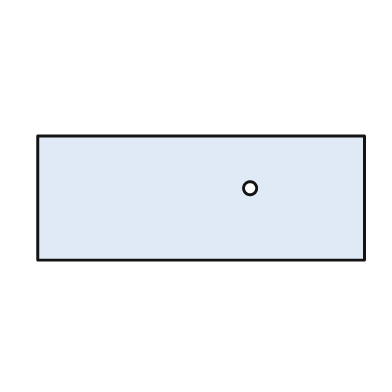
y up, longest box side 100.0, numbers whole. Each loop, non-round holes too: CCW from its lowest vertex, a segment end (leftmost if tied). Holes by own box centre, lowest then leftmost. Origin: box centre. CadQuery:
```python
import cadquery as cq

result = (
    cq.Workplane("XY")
    .moveTo(-50.0, -19.0)
    .lineTo(50.0, -19.0)
    .lineTo(50.0, 19.0)
    .lineTo(-50.0, 19.0)
    .close()
    .moveTo(15.0, 3.0)
    .circle(2.0)
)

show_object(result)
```